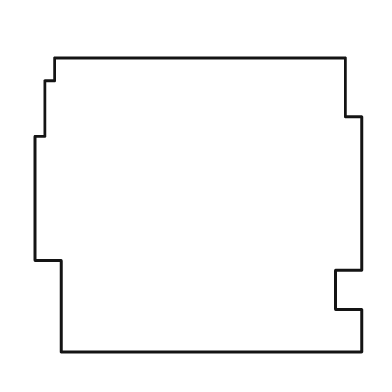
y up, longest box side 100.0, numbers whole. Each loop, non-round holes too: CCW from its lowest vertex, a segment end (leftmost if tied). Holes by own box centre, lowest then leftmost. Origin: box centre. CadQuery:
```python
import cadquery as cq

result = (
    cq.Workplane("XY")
    .moveTo(-42.0, -45.0)
    .lineTo(50.0, -45.0)
    .lineTo(50.0, -32.0)
    .lineTo(42.0, -32.0)
    .lineTo(42.0, -20.0)
    .lineTo(50.0, -20.0)
    .lineTo(50.0, 27.0)
    .lineTo(45.0, 27.0)
    .lineTo(45.0, 45.0)
    .lineTo(-44.0, 45.0)
    .lineTo(-44.0, 38.0)
    .lineTo(-47.0, 38.0)
    .lineTo(-47.0, 21.0)
    .lineTo(-50.0, 21.0)
    .lineTo(-50.0, -17.0)
    .lineTo(-42.0, -17.0)
    .close()
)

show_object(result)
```